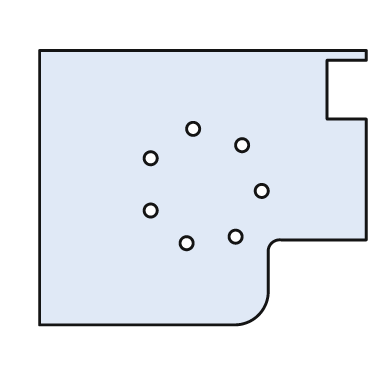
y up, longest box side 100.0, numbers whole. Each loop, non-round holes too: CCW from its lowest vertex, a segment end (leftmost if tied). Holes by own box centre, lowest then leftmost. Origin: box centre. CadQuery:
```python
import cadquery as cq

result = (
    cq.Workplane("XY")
    .moveTo(-50.0, -42.0)
    .lineTo(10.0, -42.0)
    .threePointArc((17.0, -39.0), (20.0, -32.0))
    .lineTo(20.0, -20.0)
    .threePointArc((21.0, -17.0), (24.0, -16.0))
    .lineTo(50.0, -16.0)
    .lineTo(50.0, 21.0)
    .lineTo(38.0, 21.0)
    .lineTo(38.0, 39.0)
    .lineTo(50.0, 39.0)
    .lineTo(50.0, 42.0)
    .lineTo(-50.0, 42.0)
    .close()
    .moveTo(-5.0, -17.0)
    .circle(2.0)
    .moveTo(10.0, -15.0)
    .circle(2.0)
    .moveTo(-16.0, -7.0)
    .circle(2.0)
    .moveTo(18.0, -1.0)
    .circle(2.0)
    .moveTo(-16.0, 9.0)
    .circle(2.0)
    .moveTo(12.0, 13.0)
    .circle(2.0)
    .moveTo(-3.0, 18.0)
    .circle(2.0)
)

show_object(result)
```